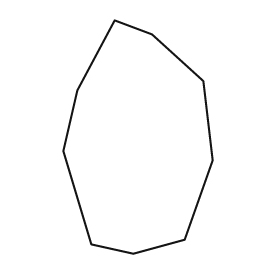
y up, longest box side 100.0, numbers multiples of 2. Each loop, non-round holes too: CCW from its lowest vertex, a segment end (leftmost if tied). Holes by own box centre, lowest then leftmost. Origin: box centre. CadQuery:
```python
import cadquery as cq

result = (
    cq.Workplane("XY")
    .moveTo(-2.0, -50.0)
    .lineTo(20.0, -44.0)
    .lineTo(32.0, -10.0)
    .lineTo(28.0, 24.0)
    .lineTo(6.0, 44.0)
    .lineTo(-10.0, 50.0)
    .lineTo(-26.0, 20.0)
    .lineTo(-32.0, -6.0)
    .lineTo(-20.0, -46.0)
    .close()
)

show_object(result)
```